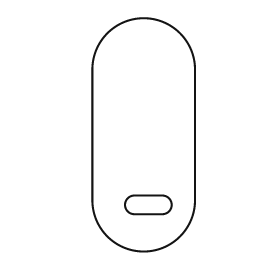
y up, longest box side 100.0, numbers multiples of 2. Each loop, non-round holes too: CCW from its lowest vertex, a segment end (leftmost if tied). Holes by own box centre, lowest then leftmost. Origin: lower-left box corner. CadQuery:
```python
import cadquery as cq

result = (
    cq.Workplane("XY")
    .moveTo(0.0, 22.0)
    .threePointArc((22.0, 0.0), (44.0, 22.0))
    .lineTo(44.0, 78.0)
    .threePointArc((22.0, 100.0), (0.0, 78.0))
    .close()
    .moveTo(18.0, 16.0)
    .lineTo(30.0, 16.0)
    .threePointArc((34.0, 20.0), (30.0, 24.0))
    .lineTo(18.0, 24.0)
    .threePointArc((14.0, 20.0), (18.0, 16.0))
    .close()
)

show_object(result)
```